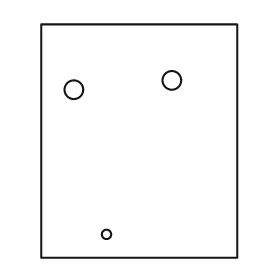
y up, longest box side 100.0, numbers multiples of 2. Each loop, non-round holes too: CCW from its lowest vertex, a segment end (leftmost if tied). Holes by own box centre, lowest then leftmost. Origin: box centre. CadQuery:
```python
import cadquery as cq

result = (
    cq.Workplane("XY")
    .moveTo(-42.0, -50.0)
    .lineTo(42.0, -50.0)
    .lineTo(42.0, 50.0)
    .lineTo(-42.0, 50.0)
    .close()
    .moveTo(-14.0, -40.0)
    .circle(2.0)
    .moveTo(-28.0, 22.0)
    .circle(4.0)
    .moveTo(14.0, 26.0)
    .circle(4.0)
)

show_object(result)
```